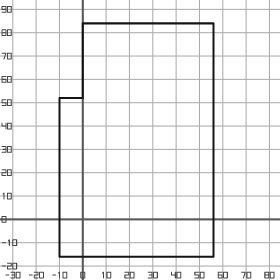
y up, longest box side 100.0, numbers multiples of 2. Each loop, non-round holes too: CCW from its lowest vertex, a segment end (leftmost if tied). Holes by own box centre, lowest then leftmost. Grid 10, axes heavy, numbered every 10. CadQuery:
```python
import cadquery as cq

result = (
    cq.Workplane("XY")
    .moveTo(-10.0, -16.0)
    .lineTo(56.0, -16.0)
    .lineTo(56.0, 84.0)
    .lineTo(0.0, 84.0)
    .lineTo(0.0, 52.0)
    .lineTo(-10.0, 52.0)
    .close()
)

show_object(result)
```